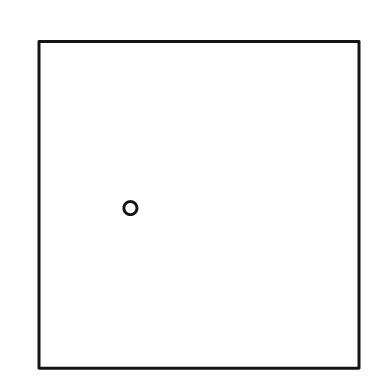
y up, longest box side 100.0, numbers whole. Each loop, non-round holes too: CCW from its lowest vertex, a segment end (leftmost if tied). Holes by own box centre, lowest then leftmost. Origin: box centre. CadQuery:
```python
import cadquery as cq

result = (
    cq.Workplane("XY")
    .moveTo(-49.0, -50.0)
    .lineTo(49.0, -50.0)
    .lineTo(49.0, 50.0)
    .lineTo(-49.0, 50.0)
    .close()
    .moveTo(-21.0, -1.0)
    .circle(2.0)
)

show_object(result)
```